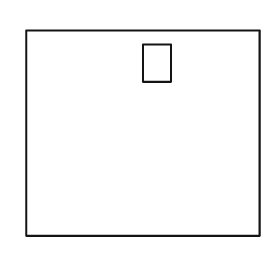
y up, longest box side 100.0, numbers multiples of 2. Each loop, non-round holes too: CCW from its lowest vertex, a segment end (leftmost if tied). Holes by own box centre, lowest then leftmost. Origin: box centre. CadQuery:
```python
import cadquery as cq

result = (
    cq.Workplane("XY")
    .moveTo(-50.0, -44.0)
    .lineTo(50.0, -44.0)
    .lineTo(50.0, 44.0)
    .lineTo(-50.0, 44.0)
    .close()
    .moveTo(0.0, 22.0)
    .lineTo(12.0, 22.0)
    .lineTo(12.0, 38.0)
    .lineTo(0.0, 38.0)
    .close()
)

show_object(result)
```